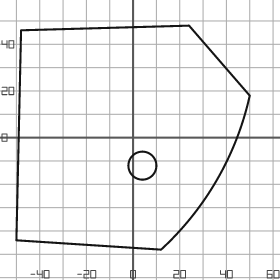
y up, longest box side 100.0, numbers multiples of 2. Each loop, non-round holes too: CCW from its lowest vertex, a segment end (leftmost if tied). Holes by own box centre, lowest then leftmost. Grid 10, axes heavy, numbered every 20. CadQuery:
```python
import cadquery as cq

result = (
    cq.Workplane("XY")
    .moveTo(12.0, -48.0)
    .threePointArc((36.0, -18.0), (50.0, 18.0))
    .lineTo(24.0, 48.0)
    .lineTo(-48.0, 46.0)
    .lineTo(-50.0, -44.0)
    .close()
    .moveTo(4.0, -12.0)
    .circle(6.0)
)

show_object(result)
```